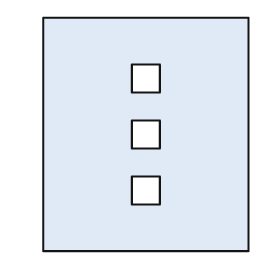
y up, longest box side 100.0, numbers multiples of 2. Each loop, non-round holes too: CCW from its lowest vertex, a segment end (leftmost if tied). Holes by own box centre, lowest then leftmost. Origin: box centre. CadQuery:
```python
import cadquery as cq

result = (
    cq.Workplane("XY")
    .moveTo(-44.0, -50.0)
    .lineTo(44.0, -50.0)
    .lineTo(44.0, 50.0)
    .lineTo(-44.0, 50.0)
    .close()
    .moveTo(-6.0, -30.0)
    .lineTo(6.0, -30.0)
    .lineTo(6.0, -18.0)
    .lineTo(-6.0, -18.0)
    .close()
    .moveTo(-6.0, -6.0)
    .lineTo(6.0, -6.0)
    .lineTo(6.0, 6.0)
    .lineTo(-6.0, 6.0)
    .close()
    .moveTo(-6.0, 18.0)
    .lineTo(6.0, 18.0)
    .lineTo(6.0, 30.0)
    .lineTo(-6.0, 30.0)
    .close()
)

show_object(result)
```